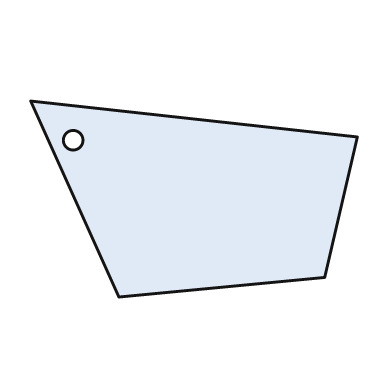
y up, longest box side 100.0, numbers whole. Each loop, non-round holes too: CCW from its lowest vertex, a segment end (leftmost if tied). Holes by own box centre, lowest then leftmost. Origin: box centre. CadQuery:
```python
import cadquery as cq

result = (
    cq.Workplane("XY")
    .moveTo(-23.0, -30.0)
    .lineTo(40.0, -24.0)
    .lineTo(50.0, 19.0)
    .lineTo(-50.0, 30.0)
    .close()
    .moveTo(-37.0, 18.0)
    .circle(3.0)
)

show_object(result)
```